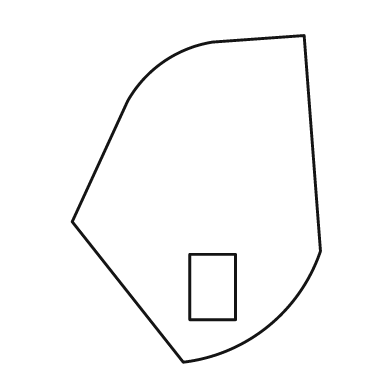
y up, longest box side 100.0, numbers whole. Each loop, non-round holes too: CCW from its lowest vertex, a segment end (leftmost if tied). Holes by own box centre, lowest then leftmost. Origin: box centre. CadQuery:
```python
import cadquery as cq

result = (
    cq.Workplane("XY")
    .moveTo(-4.0, -50.0)
    .threePointArc((22.0, -39.0), (38.0, -16.0))
    .lineTo(33.0, 50.0)
    .lineTo(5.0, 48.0)
    .threePointArc((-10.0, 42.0), (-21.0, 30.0))
    .lineTo(-38.0, -7.0)
    .close()
    .moveTo(-2.0, -37.0)
    .lineTo(12.0, -37.0)
    .lineTo(12.0, -17.0)
    .lineTo(-2.0, -17.0)
    .close()
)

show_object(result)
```